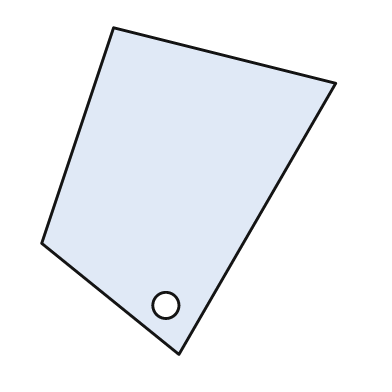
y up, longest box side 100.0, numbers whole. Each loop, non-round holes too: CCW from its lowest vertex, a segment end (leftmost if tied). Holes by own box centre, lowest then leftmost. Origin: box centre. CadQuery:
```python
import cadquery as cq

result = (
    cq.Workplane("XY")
    .moveTo(-3.0, -50.0)
    .lineTo(45.0, 33.0)
    .lineTo(-23.0, 50.0)
    .lineTo(-45.0, -16.0)
    .close()
    .moveTo(-7.0, -35.0)
    .circle(4.0)
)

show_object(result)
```